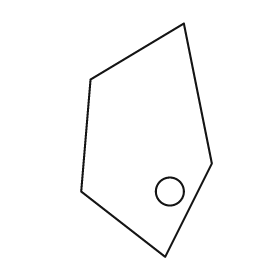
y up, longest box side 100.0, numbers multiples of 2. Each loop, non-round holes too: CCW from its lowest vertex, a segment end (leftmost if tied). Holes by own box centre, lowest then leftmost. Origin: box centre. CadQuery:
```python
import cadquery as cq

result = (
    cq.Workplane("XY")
    .moveTo(8.0, -50.0)
    .lineTo(28.0, -10.0)
    .lineTo(16.0, 50.0)
    .lineTo(-24.0, 26.0)
    .lineTo(-28.0, -22.0)
    .close()
    .moveTo(10.0, -22.0)
    .circle(6.0)
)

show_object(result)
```